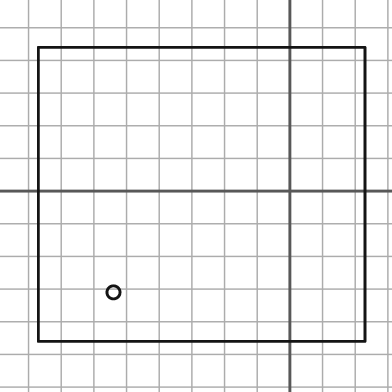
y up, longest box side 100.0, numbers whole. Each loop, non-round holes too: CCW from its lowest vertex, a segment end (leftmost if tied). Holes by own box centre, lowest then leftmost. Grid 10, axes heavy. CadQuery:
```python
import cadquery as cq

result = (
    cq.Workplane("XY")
    .moveTo(-77.0, -46.0)
    .lineTo(23.0, -46.0)
    .lineTo(23.0, 44.0)
    .lineTo(-77.0, 44.0)
    .close()
    .moveTo(-54.0, -31.0)
    .circle(2.0)
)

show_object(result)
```